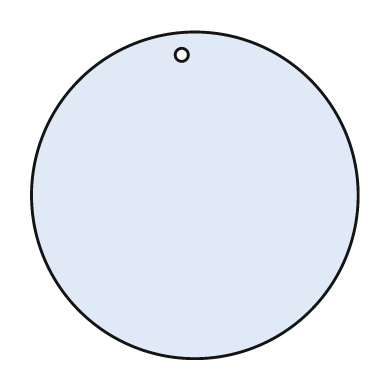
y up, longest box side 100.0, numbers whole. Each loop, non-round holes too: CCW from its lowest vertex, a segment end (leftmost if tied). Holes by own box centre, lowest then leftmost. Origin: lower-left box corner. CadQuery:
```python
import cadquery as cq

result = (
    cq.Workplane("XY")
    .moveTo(50.0, 50.0)
    .circle(50.0)
    .moveTo(46.0, 93.0)
    .circle(2.0)
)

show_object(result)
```